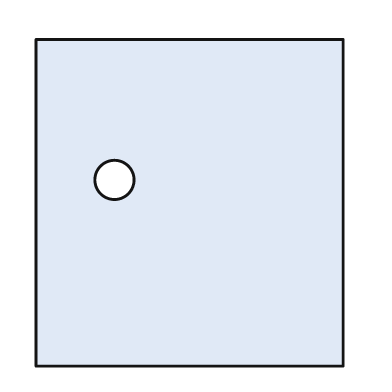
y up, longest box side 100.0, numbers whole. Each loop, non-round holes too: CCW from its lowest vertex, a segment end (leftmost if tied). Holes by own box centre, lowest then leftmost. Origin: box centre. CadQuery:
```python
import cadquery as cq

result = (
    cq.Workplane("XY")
    .moveTo(-47.0, -50.0)
    .lineTo(47.0, -50.0)
    .lineTo(47.0, 50.0)
    .lineTo(-47.0, 50.0)
    .close()
    .moveTo(-23.0, 7.0)
    .circle(6.0)
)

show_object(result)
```